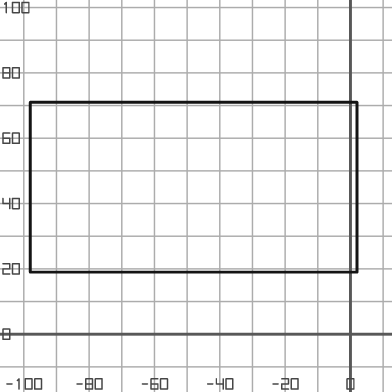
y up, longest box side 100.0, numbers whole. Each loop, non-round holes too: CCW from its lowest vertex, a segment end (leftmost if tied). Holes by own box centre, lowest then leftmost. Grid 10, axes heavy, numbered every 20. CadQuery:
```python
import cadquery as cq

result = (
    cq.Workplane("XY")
    .moveTo(-98.0, 19.0)
    .lineTo(2.0, 19.0)
    .lineTo(2.0, 71.0)
    .lineTo(-98.0, 71.0)
    .close()
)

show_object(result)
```